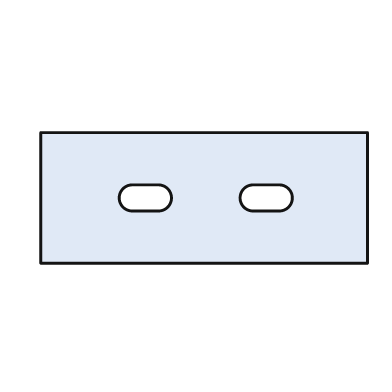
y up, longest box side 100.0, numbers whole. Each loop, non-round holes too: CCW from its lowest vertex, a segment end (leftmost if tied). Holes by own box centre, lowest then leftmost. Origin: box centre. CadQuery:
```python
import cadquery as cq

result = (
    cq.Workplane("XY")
    .moveTo(-50.0, -20.0)
    .lineTo(50.0, -20.0)
    .lineTo(50.0, 20.0)
    .lineTo(-50.0, 20.0)
    .close()
    .moveTo(-22.0, -4.0)
    .lineTo(-14.0, -4.0)
    .threePointArc((-10.0, 0.0), (-14.0, 4.0))
    .lineTo(-22.0, 4.0)
    .threePointArc((-26.0, 0.0), (-22.0, -4.0))
    .close()
    .moveTo(15.0, -4.0)
    .lineTo(23.0, -4.0)
    .threePointArc((27.0, 0.0), (23.0, 4.0))
    .lineTo(15.0, 4.0)
    .threePointArc((11.0, 0.0), (15.0, -4.0))
    .close()
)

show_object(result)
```